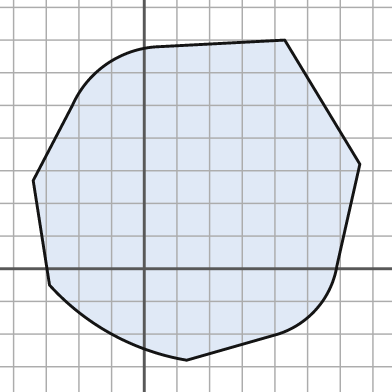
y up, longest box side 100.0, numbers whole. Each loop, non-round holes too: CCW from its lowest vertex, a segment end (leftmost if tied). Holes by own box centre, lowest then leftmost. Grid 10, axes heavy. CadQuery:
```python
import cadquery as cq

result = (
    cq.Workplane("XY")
    .moveTo(13.0, -28.0)
    .lineTo(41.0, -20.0)
    .threePointArc((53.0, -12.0), (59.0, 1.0))
    .lineTo(66.0, 32.0)
    .lineTo(43.0, 70.0)
    .lineTo(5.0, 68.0)
    .threePointArc((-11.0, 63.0), (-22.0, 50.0))
    .lineTo(-34.0, 27.0)
    .lineTo(-29.0, -5.0)
    .threePointArc((-10.0, -20.0), (13.0, -28.0))
    .close()
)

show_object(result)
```